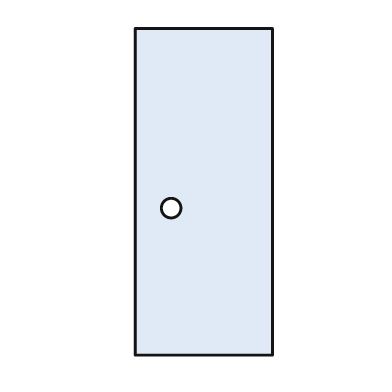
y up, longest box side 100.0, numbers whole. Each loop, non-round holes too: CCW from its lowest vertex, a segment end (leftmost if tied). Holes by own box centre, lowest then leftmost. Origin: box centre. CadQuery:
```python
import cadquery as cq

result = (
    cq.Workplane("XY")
    .moveTo(-21.0, -50.0)
    .lineTo(21.0, -50.0)
    .lineTo(21.0, 50.0)
    .lineTo(-21.0, 50.0)
    .close()
    .moveTo(-10.0, -5.0)
    .circle(3.0)
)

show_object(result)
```